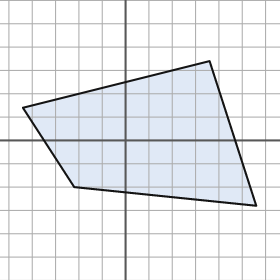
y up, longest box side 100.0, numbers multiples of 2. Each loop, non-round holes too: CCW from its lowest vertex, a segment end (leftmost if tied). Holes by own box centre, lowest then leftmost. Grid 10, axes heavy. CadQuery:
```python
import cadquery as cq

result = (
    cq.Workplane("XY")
    .moveTo(56.0, -28.0)
    .lineTo(36.0, 34.0)
    .lineTo(-44.0, 14.0)
    .lineTo(-22.0, -20.0)
    .close()
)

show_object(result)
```